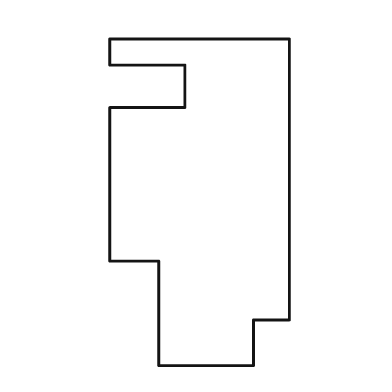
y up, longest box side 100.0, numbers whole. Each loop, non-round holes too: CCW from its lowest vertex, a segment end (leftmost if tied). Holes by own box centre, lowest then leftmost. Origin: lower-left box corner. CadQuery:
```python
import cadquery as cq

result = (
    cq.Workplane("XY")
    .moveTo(15.0, 0.0)
    .lineTo(44.0, 0.0)
    .lineTo(44.0, 14.0)
    .lineTo(55.0, 14.0)
    .lineTo(55.0, 100.0)
    .lineTo(0.0, 100.0)
    .lineTo(0.0, 92.0)
    .lineTo(23.0, 92.0)
    .lineTo(23.0, 79.0)
    .lineTo(0.0, 79.0)
    .lineTo(0.0, 32.0)
    .lineTo(15.0, 32.0)
    .close()
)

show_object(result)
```